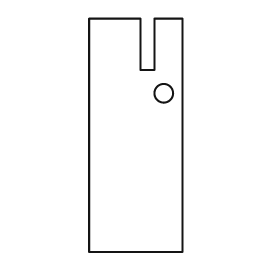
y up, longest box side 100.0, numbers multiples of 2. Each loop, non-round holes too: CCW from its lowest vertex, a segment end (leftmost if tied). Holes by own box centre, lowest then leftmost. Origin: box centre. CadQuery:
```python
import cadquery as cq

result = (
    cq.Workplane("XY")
    .moveTo(-20.0, -50.0)
    .lineTo(20.0, -50.0)
    .lineTo(20.0, 50.0)
    .lineTo(8.0, 50.0)
    .lineTo(8.0, 28.0)
    .lineTo(2.0, 28.0)
    .lineTo(2.0, 50.0)
    .lineTo(-20.0, 50.0)
    .close()
    .moveTo(12.0, 18.0)
    .circle(4.0)
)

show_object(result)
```